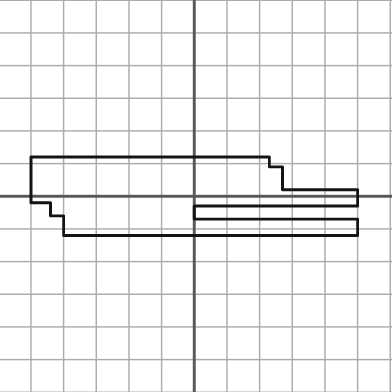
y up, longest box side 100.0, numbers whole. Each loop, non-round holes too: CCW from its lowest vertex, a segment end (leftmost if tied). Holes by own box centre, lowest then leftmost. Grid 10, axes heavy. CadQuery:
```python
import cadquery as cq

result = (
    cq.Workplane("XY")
    .moveTo(-40.0, -12.0)
    .lineTo(50.0, -12.0)
    .lineTo(50.0, -7.0)
    .lineTo(0.0, -7.0)
    .lineTo(0.0, -3.0)
    .lineTo(50.0, -3.0)
    .lineTo(50.0, 2.0)
    .lineTo(27.0, 2.0)
    .lineTo(27.0, 9.0)
    .lineTo(23.0, 9.0)
    .lineTo(23.0, 12.0)
    .lineTo(-50.0, 12.0)
    .lineTo(-50.0, -2.0)
    .lineTo(-44.0, -2.0)
    .lineTo(-44.0, -6.0)
    .lineTo(-40.0, -6.0)
    .close()
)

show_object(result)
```